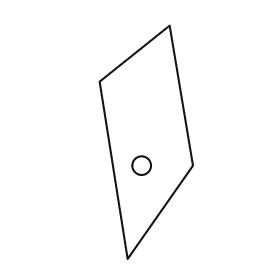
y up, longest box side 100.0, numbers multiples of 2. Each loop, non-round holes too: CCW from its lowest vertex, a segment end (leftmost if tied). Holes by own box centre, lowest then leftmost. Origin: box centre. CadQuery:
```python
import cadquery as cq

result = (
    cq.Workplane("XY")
    .moveTo(-8.0, -50.0)
    .lineTo(20.0, -10.0)
    .lineTo(10.0, 50.0)
    .lineTo(-20.0, 26.0)
    .close()
    .moveTo(-2.0, -10.0)
    .circle(4.0)
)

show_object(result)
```